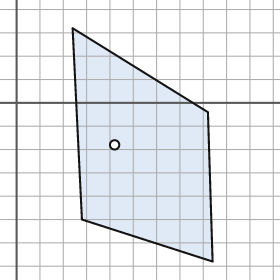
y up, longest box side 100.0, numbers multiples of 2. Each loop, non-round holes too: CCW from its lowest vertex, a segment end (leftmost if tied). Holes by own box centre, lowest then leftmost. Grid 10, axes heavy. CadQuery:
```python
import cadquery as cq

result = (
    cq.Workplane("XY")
    .moveTo(84.0, -68.0)
    .lineTo(82.0, -4.0)
    .lineTo(24.0, 32.0)
    .lineTo(28.0, -50.0)
    .close()
    .moveTo(42.0, -18.0)
    .circle(2.0)
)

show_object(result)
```